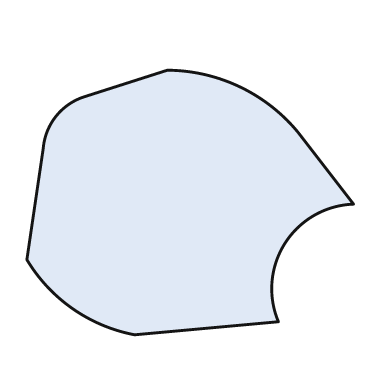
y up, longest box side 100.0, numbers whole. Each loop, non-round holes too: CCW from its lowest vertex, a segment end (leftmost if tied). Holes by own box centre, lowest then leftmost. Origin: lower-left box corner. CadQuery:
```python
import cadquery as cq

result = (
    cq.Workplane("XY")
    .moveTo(33.0, 0.0)
    .lineTo(77.0, 4.0)
    .threePointArc((79.0, 28.0), (100.0, 40.0))
    .lineTo(83.0, 62.0)
    .threePointArc((65.0, 76.0), (43.0, 81.0))
    .lineTo(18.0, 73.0)
    .threePointArc((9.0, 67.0), (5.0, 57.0))
    .lineTo(0.0, 23.0)
    .threePointArc((14.0, 8.0), (33.0, 0.0))
    .close()
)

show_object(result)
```